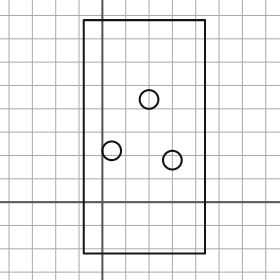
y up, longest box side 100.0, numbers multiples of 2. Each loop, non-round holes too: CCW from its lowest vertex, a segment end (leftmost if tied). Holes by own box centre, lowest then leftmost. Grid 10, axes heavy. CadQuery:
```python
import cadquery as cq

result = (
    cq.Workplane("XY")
    .moveTo(-8.0, -22.0)
    .lineTo(44.0, -22.0)
    .lineTo(44.0, 78.0)
    .lineTo(-8.0, 78.0)
    .close()
    .moveTo(30.0, 18.0)
    .circle(4.0)
    .moveTo(4.0, 22.0)
    .circle(4.0)
    .moveTo(20.0, 44.0)
    .circle(4.0)
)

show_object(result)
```